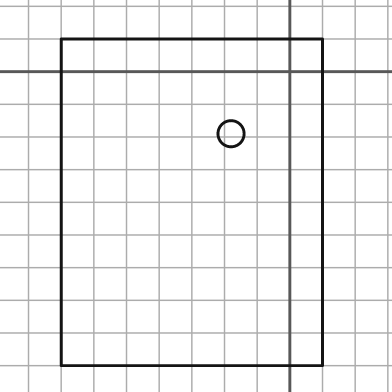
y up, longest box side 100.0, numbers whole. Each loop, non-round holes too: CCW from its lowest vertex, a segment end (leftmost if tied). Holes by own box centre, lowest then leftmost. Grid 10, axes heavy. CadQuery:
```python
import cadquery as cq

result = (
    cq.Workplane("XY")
    .moveTo(-70.0, -90.0)
    .lineTo(10.0, -90.0)
    .lineTo(10.0, 10.0)
    .lineTo(-70.0, 10.0)
    .close()
    .moveTo(-18.0, -19.0)
    .circle(4.0)
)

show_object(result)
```